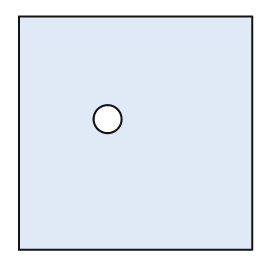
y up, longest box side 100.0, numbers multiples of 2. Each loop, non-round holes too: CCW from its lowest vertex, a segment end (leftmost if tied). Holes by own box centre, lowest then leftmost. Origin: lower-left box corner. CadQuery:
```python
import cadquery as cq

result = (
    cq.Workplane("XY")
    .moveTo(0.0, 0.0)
    .lineTo(100.0, 0.0)
    .lineTo(100.0, 100.0)
    .lineTo(0.0, 100.0)
    .close()
    .moveTo(38.0, 56.0)
    .circle(6.0)
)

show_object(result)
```